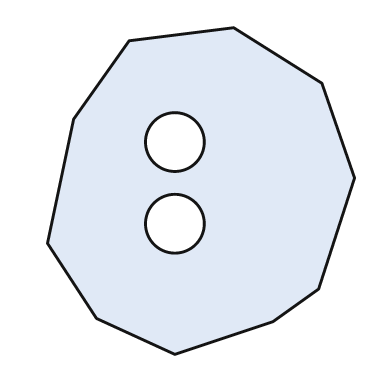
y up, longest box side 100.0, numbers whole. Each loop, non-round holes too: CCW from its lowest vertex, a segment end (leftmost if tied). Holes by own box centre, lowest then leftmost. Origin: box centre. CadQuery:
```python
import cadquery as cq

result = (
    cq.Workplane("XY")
    .moveTo(-8.0, -50.0)
    .lineTo(22.0, -40.0)
    .lineTo(36.0, -30.0)
    .lineTo(47.0, 4.0)
    .lineTo(37.0, 33.0)
    .lineTo(10.0, 50.0)
    .lineTo(-22.0, 46.0)
    .lineTo(-39.0, 22.0)
    .lineTo(-47.0, -16.0)
    .lineTo(-32.0, -39.0)
    .close()
    .moveTo(-8.0, -10.0)
    .circle(9.0)
    .moveTo(-8.0, 15.0)
    .circle(9.0)
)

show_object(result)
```